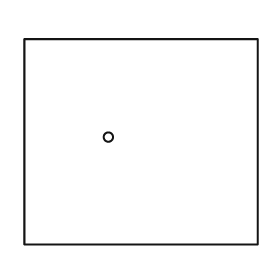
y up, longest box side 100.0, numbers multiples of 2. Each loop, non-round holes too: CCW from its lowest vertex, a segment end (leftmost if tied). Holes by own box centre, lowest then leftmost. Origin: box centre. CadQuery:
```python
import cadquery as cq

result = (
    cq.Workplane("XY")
    .moveTo(-50.0, -44.0)
    .lineTo(50.0, -44.0)
    .lineTo(50.0, 44.0)
    .lineTo(-50.0, 44.0)
    .close()
    .moveTo(-14.0, 2.0)
    .circle(2.0)
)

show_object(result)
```